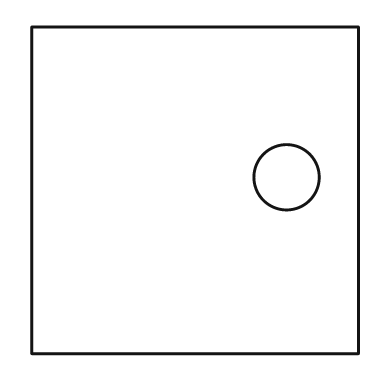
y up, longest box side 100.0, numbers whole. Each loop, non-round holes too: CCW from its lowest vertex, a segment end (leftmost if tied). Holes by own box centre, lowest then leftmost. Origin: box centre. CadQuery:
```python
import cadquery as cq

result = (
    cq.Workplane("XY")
    .moveTo(-50.0, -50.0)
    .lineTo(50.0, -50.0)
    .lineTo(50.0, 50.0)
    .lineTo(-50.0, 50.0)
    .close()
    .moveTo(28.0, 4.0)
    .circle(10.0)
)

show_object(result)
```